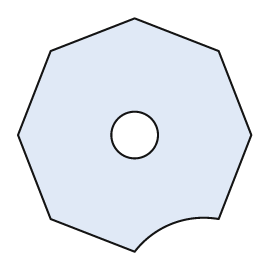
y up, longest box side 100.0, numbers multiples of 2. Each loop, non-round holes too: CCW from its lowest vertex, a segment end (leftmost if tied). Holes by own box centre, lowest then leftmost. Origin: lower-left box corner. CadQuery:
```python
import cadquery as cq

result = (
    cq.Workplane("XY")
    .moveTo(50.0, 0.0)
    .threePointArc((66.0, 12.0), (86.0, 14.0))
    .lineTo(100.0, 50.0)
    .lineTo(86.0, 86.0)
    .lineTo(50.0, 100.0)
    .lineTo(14.0, 86.0)
    .lineTo(0.0, 50.0)
    .lineTo(14.0, 14.0)
    .close()
    .moveTo(50.0, 50.0)
    .circle(10.0)
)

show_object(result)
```